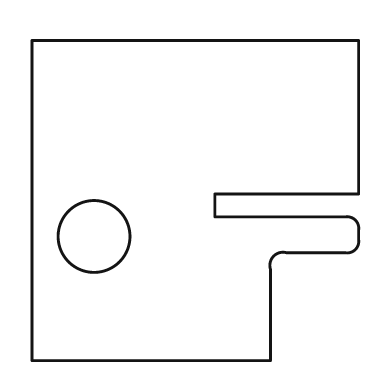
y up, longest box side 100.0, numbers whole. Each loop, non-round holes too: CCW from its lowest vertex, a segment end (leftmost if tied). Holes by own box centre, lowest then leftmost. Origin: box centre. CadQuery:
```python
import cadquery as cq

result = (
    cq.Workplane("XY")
    .moveTo(-50.0, -49.0)
    .lineTo(23.0, -49.0)
    .lineTo(23.0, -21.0)
    .threePointArc((24.0, -17.0), (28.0, -16.0))
    .lineTo(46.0, -16.0)
    .threePointArc((49.0, -15.0), (50.0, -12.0))
    .lineTo(50.0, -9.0)
    .threePointArc((49.0, -6.0), (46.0, -5.0))
    .lineTo(6.0, -5.0)
    .lineTo(6.0, 2.0)
    .lineTo(50.0, 2.0)
    .lineTo(50.0, 49.0)
    .lineTo(-50.0, 49.0)
    .close()
    .moveTo(-31.0, -11.0)
    .circle(11.0)
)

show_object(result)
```